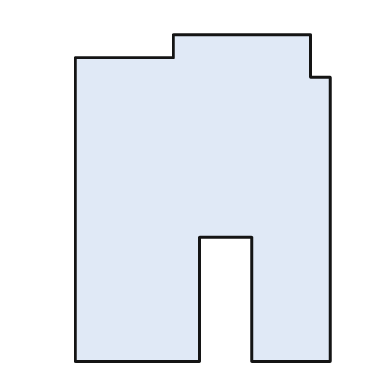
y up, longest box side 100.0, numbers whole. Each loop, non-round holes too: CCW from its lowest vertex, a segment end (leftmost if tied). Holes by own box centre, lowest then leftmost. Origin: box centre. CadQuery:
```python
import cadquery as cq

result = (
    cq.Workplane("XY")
    .moveTo(-39.0, -50.0)
    .lineTo(-1.0, -50.0)
    .lineTo(-1.0, -12.0)
    .lineTo(15.0, -12.0)
    .lineTo(15.0, -50.0)
    .lineTo(39.0, -50.0)
    .lineTo(39.0, 37.0)
    .lineTo(33.0, 37.0)
    .lineTo(33.0, 50.0)
    .lineTo(-9.0, 50.0)
    .lineTo(-9.0, 43.0)
    .lineTo(-39.0, 43.0)
    .close()
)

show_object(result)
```